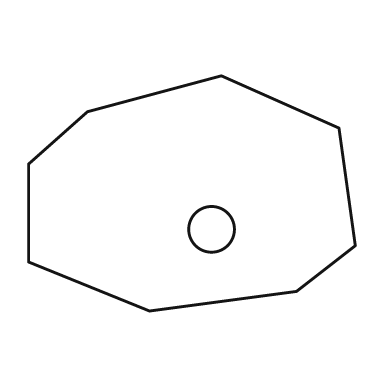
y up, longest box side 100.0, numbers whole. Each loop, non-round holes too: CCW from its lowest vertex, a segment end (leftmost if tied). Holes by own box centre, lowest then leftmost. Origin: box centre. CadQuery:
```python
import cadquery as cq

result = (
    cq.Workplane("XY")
    .moveTo(-13.0, -36.0)
    .lineTo(32.0, -30.0)
    .lineTo(50.0, -16.0)
    .lineTo(45.0, 20.0)
    .lineTo(9.0, 36.0)
    .lineTo(-32.0, 25.0)
    .lineTo(-50.0, 9.0)
    .lineTo(-50.0, -21.0)
    .close()
    .moveTo(6.0, -11.0)
    .circle(7.0)
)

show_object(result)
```